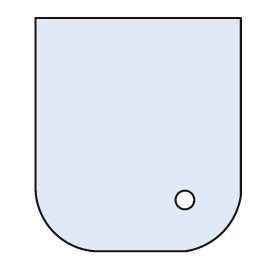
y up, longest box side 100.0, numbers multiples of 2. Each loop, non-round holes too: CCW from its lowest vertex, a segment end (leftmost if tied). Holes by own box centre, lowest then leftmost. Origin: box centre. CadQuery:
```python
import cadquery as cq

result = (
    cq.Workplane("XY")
    .moveTo(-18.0, -50.0)
    .lineTo(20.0, -50.0)
    .threePointArc((36.0, -42.0), (44.0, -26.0))
    .lineTo(44.0, 50.0)
    .lineTo(-44.0, 50.0)
    .lineTo(-44.0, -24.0)
    .threePointArc((-36.0, -42.0), (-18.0, -50.0))
    .close()
    .moveTo(20.0, -28.0)
    .circle(4.0)
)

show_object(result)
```